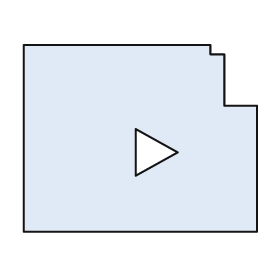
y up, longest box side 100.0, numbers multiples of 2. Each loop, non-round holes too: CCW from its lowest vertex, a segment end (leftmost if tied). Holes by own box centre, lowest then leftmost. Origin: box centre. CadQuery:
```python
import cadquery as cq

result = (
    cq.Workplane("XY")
    .moveTo(-50.0, -40.0)
    .lineTo(50.0, -40.0)
    .lineTo(50.0, 14.0)
    .lineTo(36.0, 14.0)
    .lineTo(36.0, 36.0)
    .lineTo(30.0, 36.0)
    .lineTo(30.0, 40.0)
    .lineTo(-50.0, 40.0)
    .close()
    .moveTo(-2.0, -16.0)
    .lineTo(16.0, -6.0)
    .lineTo(-2.0, 4.0)
    .close()
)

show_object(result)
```